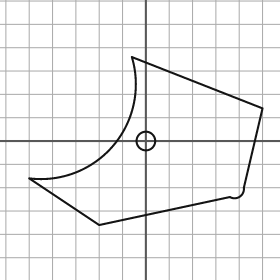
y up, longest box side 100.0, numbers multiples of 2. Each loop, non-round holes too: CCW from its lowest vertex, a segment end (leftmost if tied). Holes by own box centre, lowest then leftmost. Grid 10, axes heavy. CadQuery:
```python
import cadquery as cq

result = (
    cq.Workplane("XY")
    .moveTo(-20.0, -36.0)
    .lineTo(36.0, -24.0)
    .threePointArc((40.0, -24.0), (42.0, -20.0))
    .lineTo(50.0, 14.0)
    .lineTo(-6.0, 36.0)
    .threePointArc((-14.0, -2.0), (-50.0, -16.0))
    .close()
    .moveTo(0.0, 0.0)
    .circle(4.0)
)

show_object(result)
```